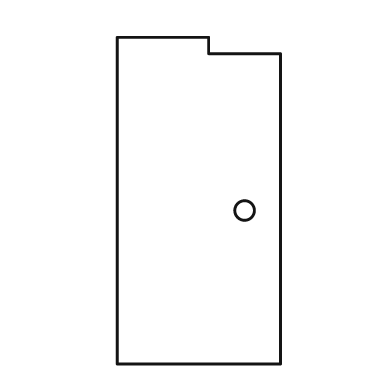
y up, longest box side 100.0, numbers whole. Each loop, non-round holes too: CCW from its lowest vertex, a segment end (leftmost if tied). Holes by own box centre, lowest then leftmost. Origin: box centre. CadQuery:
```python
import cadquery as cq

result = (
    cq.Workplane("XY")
    .moveTo(-25.0, -50.0)
    .lineTo(25.0, -50.0)
    .lineTo(25.0, 45.0)
    .lineTo(3.0, 45.0)
    .lineTo(3.0, 50.0)
    .lineTo(-25.0, 50.0)
    .close()
    .moveTo(14.0, -3.0)
    .circle(3.0)
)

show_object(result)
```